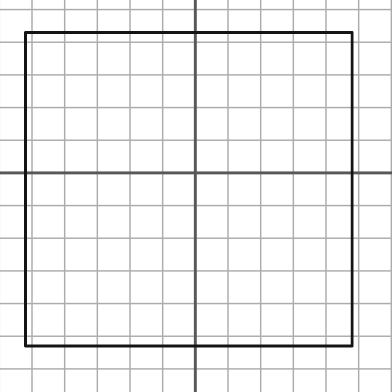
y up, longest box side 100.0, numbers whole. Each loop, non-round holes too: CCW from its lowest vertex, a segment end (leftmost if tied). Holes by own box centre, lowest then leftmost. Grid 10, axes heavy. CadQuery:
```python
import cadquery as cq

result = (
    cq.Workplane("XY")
    .moveTo(-52.0, -53.0)
    .lineTo(48.0, -53.0)
    .lineTo(48.0, 43.0)
    .lineTo(-52.0, 43.0)
    .close()
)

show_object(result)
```